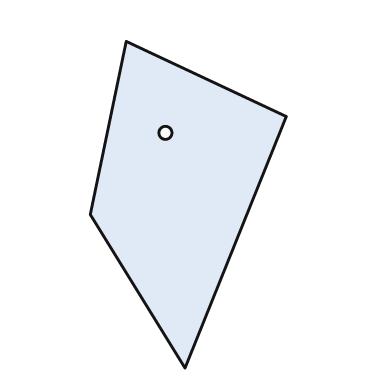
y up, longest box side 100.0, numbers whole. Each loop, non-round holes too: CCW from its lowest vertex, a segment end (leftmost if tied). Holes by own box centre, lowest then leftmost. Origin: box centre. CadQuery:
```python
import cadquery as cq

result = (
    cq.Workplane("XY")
    .moveTo(-1.0, -50.0)
    .lineTo(30.0, 27.0)
    .lineTo(-19.0, 50.0)
    .lineTo(-30.0, -3.0)
    .close()
    .moveTo(-7.0, 22.0)
    .circle(2.0)
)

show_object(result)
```